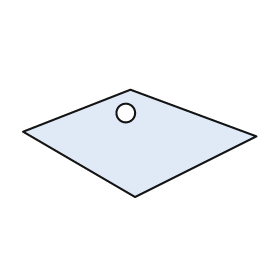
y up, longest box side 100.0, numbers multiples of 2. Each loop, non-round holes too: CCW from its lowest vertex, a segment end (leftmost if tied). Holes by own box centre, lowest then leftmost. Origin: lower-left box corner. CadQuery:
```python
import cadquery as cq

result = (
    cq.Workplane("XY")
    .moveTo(48.0, 0.0)
    .lineTo(100.0, 26.0)
    .lineTo(46.0, 46.0)
    .lineTo(0.0, 28.0)
    .close()
    .moveTo(44.0, 36.0)
    .circle(4.0)
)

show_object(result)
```